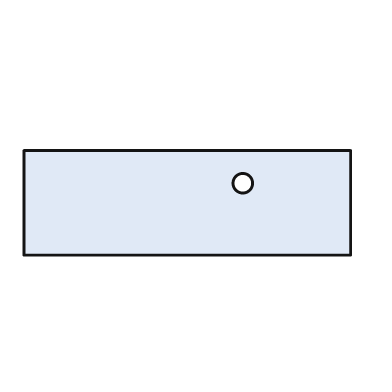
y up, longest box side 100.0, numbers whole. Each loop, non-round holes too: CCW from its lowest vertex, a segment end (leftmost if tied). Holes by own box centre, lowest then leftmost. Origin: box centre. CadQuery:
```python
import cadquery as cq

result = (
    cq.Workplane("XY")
    .moveTo(-50.0, -16.0)
    .lineTo(50.0, -16.0)
    .lineTo(50.0, 16.0)
    .lineTo(-50.0, 16.0)
    .close()
    .moveTo(17.0, 6.0)
    .circle(3.0)
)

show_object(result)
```